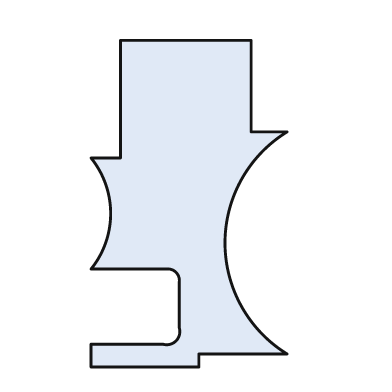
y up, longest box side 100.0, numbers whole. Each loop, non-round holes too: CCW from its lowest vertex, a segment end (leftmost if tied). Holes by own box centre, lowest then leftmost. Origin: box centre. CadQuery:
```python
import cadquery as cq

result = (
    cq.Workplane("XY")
    .moveTo(-30.0, -50.0)
    .lineTo(3.0, -50.0)
    .lineTo(3.0, -46.0)
    .lineTo(30.0, -46.0)
    .threePointArc((11.0, -12.0), (30.0, 22.0))
    .lineTo(19.0, 22.0)
    .lineTo(19.0, 50.0)
    .lineTo(-21.0, 50.0)
    .lineTo(-21.0, 14.0)
    .lineTo(-30.0, 14.0)
    .threePointArc((-24.0, -3.0), (-30.0, -20.0))
    .lineTo(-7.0, -20.0)
    .threePointArc((-4.0, -21.0), (-3.0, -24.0))
    .lineTo(-3.0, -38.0)
    .threePointArc((-4.0, -42.0), (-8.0, -43.0))
    .lineTo(-30.0, -43.0)
    .close()
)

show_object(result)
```